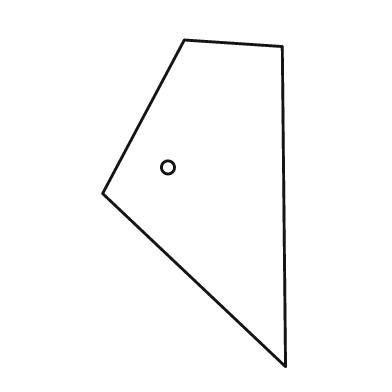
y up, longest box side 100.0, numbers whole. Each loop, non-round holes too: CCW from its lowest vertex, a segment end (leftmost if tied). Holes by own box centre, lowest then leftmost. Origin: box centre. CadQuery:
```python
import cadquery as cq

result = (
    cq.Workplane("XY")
    .moveTo(28.0, -50.0)
    .lineTo(27.0, 48.0)
    .lineTo(-3.0, 50.0)
    .lineTo(-28.0, 3.0)
    .close()
    .moveTo(-8.0, 11.0)
    .circle(2.0)
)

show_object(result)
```